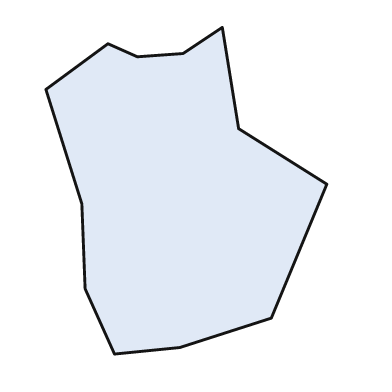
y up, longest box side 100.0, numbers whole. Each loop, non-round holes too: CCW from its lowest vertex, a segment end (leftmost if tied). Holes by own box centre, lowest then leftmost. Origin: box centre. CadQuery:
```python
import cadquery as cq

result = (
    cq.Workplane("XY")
    .moveTo(-22.0, -50.0)
    .lineTo(-2.0, -48.0)
    .lineTo(26.0, -39.0)
    .lineTo(43.0, 2.0)
    .lineTo(16.0, 19.0)
    .lineTo(11.0, 50.0)
    .lineTo(-1.0, 42.0)
    .lineTo(-15.0, 41.0)
    .lineTo(-24.0, 45.0)
    .lineTo(-43.0, 31.0)
    .lineTo(-32.0, -4.0)
    .lineTo(-31.0, -30.0)
    .close()
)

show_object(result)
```